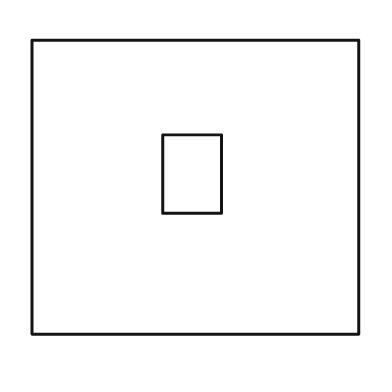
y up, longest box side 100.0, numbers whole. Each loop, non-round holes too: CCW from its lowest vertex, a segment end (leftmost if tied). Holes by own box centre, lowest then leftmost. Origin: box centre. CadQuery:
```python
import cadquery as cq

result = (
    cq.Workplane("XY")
    .moveTo(-50.0, -45.0)
    .lineTo(50.0, -45.0)
    .lineTo(50.0, 45.0)
    .lineTo(-50.0, 45.0)
    .close()
    .moveTo(-10.0, -8.0)
    .lineTo(8.0, -8.0)
    .lineTo(8.0, 16.0)
    .lineTo(-10.0, 16.0)
    .close()
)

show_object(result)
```